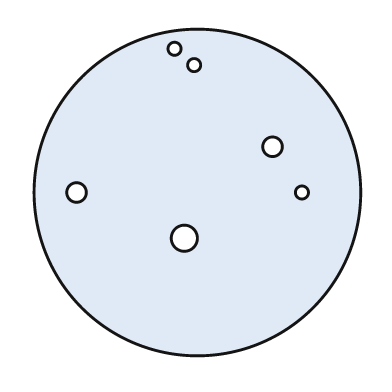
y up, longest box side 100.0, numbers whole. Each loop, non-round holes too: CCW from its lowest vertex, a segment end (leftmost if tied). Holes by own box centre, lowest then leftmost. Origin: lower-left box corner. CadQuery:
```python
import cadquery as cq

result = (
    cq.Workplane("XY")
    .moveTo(50.0, 50.0)
    .circle(50.0)
    .moveTo(46.0, 36.0)
    .circle(4.0)
    .moveTo(13.0, 50.0)
    .circle(3.0)
    .moveTo(82.0, 50.0)
    .circle(2.0)
    .moveTo(73.0, 64.0)
    .circle(3.0)
    .moveTo(49.0, 89.0)
    .circle(2.0)
    .moveTo(43.0, 94.0)
    .circle(2.0)
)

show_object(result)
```